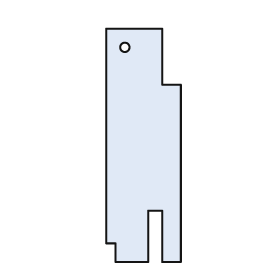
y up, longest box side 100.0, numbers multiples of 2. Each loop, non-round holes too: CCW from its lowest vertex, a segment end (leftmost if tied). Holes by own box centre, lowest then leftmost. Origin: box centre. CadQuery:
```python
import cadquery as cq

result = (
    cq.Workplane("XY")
    .moveTo(-12.0, -50.0)
    .lineTo(2.0, -50.0)
    .lineTo(2.0, -28.0)
    .lineTo(8.0, -28.0)
    .lineTo(8.0, -50.0)
    .lineTo(16.0, -50.0)
    .lineTo(16.0, 26.0)
    .lineTo(8.0, 26.0)
    .lineTo(8.0, 50.0)
    .lineTo(-16.0, 50.0)
    .lineTo(-16.0, -42.0)
    .lineTo(-12.0, -42.0)
    .close()
    .moveTo(-8.0, 42.0)
    .circle(2.0)
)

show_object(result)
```